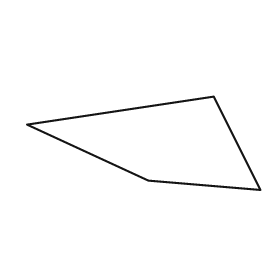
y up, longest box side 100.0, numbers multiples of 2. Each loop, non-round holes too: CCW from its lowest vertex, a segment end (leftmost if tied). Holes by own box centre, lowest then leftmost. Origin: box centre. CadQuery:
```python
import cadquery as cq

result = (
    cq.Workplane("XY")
    .moveTo(50.0, -20.0)
    .lineTo(30.0, 20.0)
    .lineTo(-50.0, 8.0)
    .lineTo(2.0, -16.0)
    .close()
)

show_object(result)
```